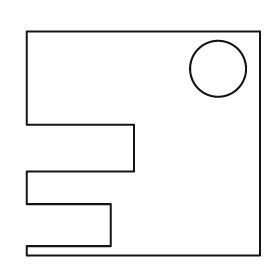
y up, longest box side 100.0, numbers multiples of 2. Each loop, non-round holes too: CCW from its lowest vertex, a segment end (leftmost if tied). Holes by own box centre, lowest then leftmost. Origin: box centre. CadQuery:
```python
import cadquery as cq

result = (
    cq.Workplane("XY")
    .moveTo(-50.0, -48.0)
    .lineTo(50.0, -48.0)
    .lineTo(50.0, 48.0)
    .lineTo(-50.0, 48.0)
    .lineTo(-50.0, 8.0)
    .lineTo(-4.0, 8.0)
    .lineTo(-4.0, -12.0)
    .lineTo(-50.0, -12.0)
    .lineTo(-50.0, -26.0)
    .lineTo(-14.0, -26.0)
    .lineTo(-14.0, -44.0)
    .lineTo(-50.0, -44.0)
    .close()
    .moveTo(32.0, 32.0)
    .circle(12.0)
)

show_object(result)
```